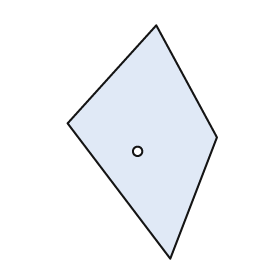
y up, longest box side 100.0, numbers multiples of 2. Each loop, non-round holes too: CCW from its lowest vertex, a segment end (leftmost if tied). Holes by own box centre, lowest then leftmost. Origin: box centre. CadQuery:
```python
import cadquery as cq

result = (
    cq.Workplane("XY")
    .moveTo(12.0, -50.0)
    .lineTo(32.0, 2.0)
    .lineTo(6.0, 50.0)
    .lineTo(-32.0, 8.0)
    .close()
    .moveTo(-2.0, -4.0)
    .circle(2.0)
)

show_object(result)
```